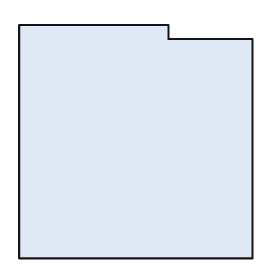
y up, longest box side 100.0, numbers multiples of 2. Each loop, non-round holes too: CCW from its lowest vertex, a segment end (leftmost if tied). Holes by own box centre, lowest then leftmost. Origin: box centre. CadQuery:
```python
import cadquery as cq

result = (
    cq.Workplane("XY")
    .moveTo(-50.0, -50.0)
    .lineTo(50.0, -50.0)
    .lineTo(50.0, 44.0)
    .lineTo(14.0, 44.0)
    .lineTo(14.0, 50.0)
    .lineTo(-50.0, 50.0)
    .close()
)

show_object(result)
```